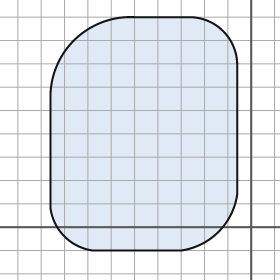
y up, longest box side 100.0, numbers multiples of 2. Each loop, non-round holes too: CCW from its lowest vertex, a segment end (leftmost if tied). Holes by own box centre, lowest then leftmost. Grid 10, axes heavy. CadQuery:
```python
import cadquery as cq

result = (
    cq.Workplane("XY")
    .moveTo(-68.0, -10.0)
    .lineTo(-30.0, -10.0)
    .threePointArc((-14.0, -2.0), (-6.0, 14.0))
    .lineTo(-6.0, 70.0)
    .threePointArc((-12.0, 84.0), (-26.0, 90.0))
    .lineTo(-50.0, 90.0)
    .threePointArc((-76.0, 80.0), (-86.0, 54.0))
    .lineTo(-86.0, 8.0)
    .threePointArc((-80.0, -4.0), (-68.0, -10.0))
    .close()
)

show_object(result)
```